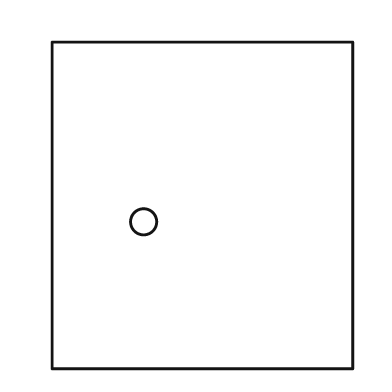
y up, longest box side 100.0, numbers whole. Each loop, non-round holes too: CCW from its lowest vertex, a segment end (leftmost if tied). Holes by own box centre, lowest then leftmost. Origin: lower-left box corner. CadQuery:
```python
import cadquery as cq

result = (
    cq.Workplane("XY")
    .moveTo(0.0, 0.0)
    .lineTo(92.0, 0.0)
    .lineTo(92.0, 100.0)
    .lineTo(0.0, 100.0)
    .close()
    .moveTo(28.0, 45.0)
    .circle(4.0)
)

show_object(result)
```